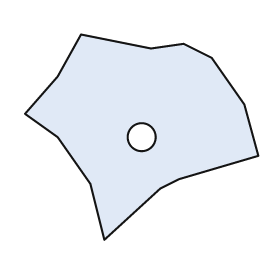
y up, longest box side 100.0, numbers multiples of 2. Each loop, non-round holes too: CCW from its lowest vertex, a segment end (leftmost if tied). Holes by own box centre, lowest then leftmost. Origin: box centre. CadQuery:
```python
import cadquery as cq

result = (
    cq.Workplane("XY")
    .moveTo(-16.0, -44.0)
    .lineTo(8.0, -22.0)
    .lineTo(16.0, -18.0)
    .lineTo(50.0, -8.0)
    .lineTo(44.0, 14.0)
    .lineTo(30.0, 34.0)
    .lineTo(18.0, 40.0)
    .lineTo(4.0, 38.0)
    .lineTo(-26.0, 44.0)
    .lineTo(-36.0, 26.0)
    .lineTo(-50.0, 10.0)
    .lineTo(-36.0, 0.0)
    .lineTo(-22.0, -20.0)
    .close()
    .moveTo(0.0, 0.0)
    .circle(6.0)
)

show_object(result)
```